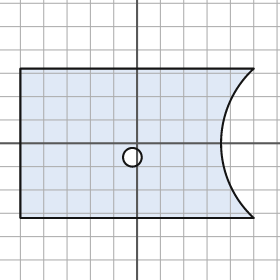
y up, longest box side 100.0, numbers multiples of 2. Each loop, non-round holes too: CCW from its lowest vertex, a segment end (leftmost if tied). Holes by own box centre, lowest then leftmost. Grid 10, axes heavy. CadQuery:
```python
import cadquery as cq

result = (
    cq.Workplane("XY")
    .moveTo(-50.0, -32.0)
    .lineTo(50.0, -32.0)
    .threePointArc((36.0, 0.0), (50.0, 32.0))
    .lineTo(-50.0, 32.0)
    .close()
    .moveTo(-2.0, -6.0)
    .circle(4.0)
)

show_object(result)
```